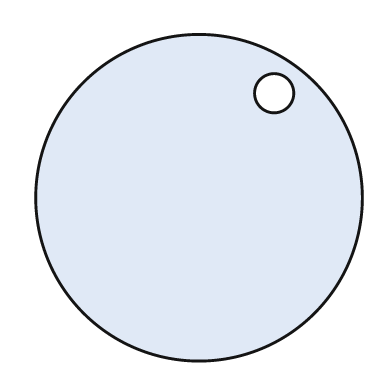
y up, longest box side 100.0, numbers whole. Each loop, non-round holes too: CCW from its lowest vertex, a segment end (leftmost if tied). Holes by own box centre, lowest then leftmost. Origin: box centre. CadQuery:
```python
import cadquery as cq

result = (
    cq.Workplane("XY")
    .moveTo(0.0, 0.0)
    .circle(50.0)
    .moveTo(23.0, 32.0)
    .circle(6.0)
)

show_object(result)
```